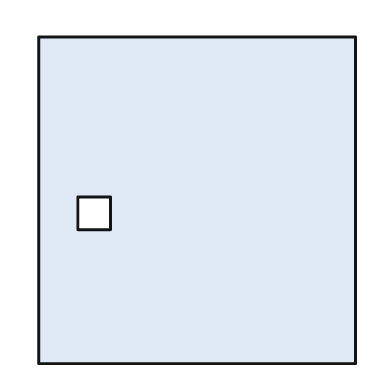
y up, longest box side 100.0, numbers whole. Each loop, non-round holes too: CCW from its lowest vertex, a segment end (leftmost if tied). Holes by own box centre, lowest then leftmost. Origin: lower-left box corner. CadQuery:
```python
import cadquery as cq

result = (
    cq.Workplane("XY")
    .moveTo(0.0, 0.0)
    .lineTo(97.0, 0.0)
    .lineTo(97.0, 100.0)
    .lineTo(0.0, 100.0)
    .close()
    .moveTo(12.0, 41.0)
    .lineTo(22.0, 41.0)
    .lineTo(22.0, 51.0)
    .lineTo(12.0, 51.0)
    .close()
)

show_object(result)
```